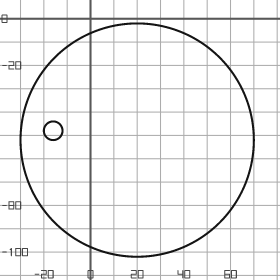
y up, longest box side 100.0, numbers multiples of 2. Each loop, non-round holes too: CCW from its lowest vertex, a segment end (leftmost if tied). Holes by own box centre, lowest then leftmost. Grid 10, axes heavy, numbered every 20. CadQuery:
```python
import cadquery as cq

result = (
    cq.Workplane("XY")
    .moveTo(20.0, -52.0)
    .circle(50.0)
    .moveTo(-16.0, -48.0)
    .circle(4.0)
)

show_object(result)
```